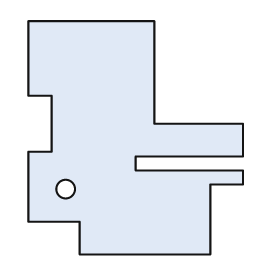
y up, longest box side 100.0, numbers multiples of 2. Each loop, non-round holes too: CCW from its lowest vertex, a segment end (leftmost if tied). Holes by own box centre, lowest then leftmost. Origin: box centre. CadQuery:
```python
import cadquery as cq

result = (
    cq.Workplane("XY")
    .moveTo(-24.0, -50.0)
    .lineTo(32.0, -50.0)
    .lineTo(32.0, -20.0)
    .lineTo(46.0, -20.0)
    .lineTo(46.0, -14.0)
    .lineTo(0.0, -14.0)
    .lineTo(0.0, -8.0)
    .lineTo(46.0, -8.0)
    .lineTo(46.0, 6.0)
    .lineTo(8.0, 6.0)
    .lineTo(8.0, 50.0)
    .lineTo(-46.0, 50.0)
    .lineTo(-46.0, 18.0)
    .lineTo(-36.0, 18.0)
    .lineTo(-36.0, -6.0)
    .lineTo(-46.0, -6.0)
    .lineTo(-46.0, -36.0)
    .lineTo(-24.0, -36.0)
    .close()
    .moveTo(-30.0, -22.0)
    .circle(4.0)
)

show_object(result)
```